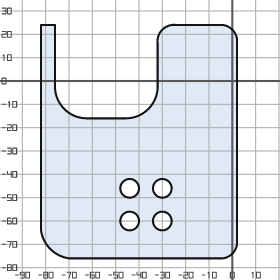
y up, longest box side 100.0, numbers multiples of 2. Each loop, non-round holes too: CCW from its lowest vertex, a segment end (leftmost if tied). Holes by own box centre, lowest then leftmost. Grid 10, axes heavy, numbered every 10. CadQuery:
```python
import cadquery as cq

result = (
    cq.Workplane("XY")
    .moveTo(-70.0, -76.0)
    .lineTo(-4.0, -76.0)
    .threePointArc((0.0, -74.0), (2.0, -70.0))
    .lineTo(2.0, 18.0)
    .threePointArc((0.0, 22.0), (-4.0, 24.0))
    .lineTo(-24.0, 24.0)
    .threePointArc((-30.0, 22.0), (-32.0, 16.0))
    .lineTo(-32.0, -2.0)
    .threePointArc((-36.0, -12.0), (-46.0, -16.0))
    .lineTo(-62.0, -16.0)
    .threePointArc((-72.0, -12.0), (-76.0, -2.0))
    .lineTo(-76.0, 24.0)
    .lineTo(-82.0, 24.0)
    .lineTo(-82.0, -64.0)
    .threePointArc((-78.0, -72.0), (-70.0, -76.0))
    .close()
    .moveTo(-44.0, -60.0)
    .circle(4.0)
    .moveTo(-30.0, -60.0)
    .circle(4.0)
    .moveTo(-44.0, -46.0)
    .circle(4.0)
    .moveTo(-30.0, -46.0)
    .circle(4.0)
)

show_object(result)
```